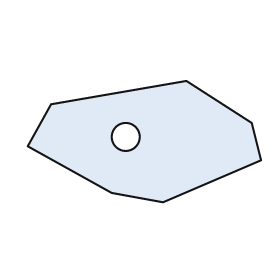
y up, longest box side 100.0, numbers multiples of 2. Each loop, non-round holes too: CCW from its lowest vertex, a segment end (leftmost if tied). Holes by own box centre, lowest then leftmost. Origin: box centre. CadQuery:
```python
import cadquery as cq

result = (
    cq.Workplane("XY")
    .moveTo(8.0, -26.0)
    .lineTo(50.0, -8.0)
    .lineTo(46.0, 8.0)
    .lineTo(18.0, 26.0)
    .lineTo(-40.0, 16.0)
    .lineTo(-50.0, -2.0)
    .lineTo(-14.0, -22.0)
    .close()
    .moveTo(-8.0, 2.0)
    .circle(6.0)
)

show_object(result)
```